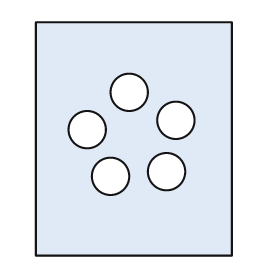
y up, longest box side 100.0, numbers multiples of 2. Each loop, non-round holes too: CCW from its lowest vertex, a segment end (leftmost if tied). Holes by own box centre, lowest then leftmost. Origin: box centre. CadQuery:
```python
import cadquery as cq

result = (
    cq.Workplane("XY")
    .moveTo(-42.0, -50.0)
    .lineTo(42.0, -50.0)
    .lineTo(42.0, 50.0)
    .lineTo(-42.0, 50.0)
    .close()
    .moveTo(-10.0, -16.0)
    .circle(8.0)
    .moveTo(14.0, -14.0)
    .circle(8.0)
    .moveTo(-20.0, 4.0)
    .circle(8.0)
    .moveTo(18.0, 8.0)
    .circle(8.0)
    .moveTo(-2.0, 20.0)
    .circle(8.0)
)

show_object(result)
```